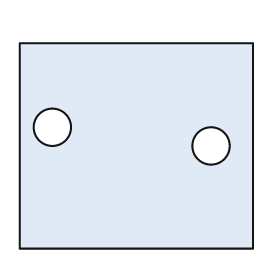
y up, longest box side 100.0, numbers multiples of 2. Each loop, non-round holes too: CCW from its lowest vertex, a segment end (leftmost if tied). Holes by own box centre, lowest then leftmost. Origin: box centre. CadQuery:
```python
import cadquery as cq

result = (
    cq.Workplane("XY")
    .moveTo(-50.0, -44.0)
    .lineTo(50.0, -44.0)
    .lineTo(50.0, 44.0)
    .lineTo(-50.0, 44.0)
    .close()
    .moveTo(32.0, 0.0)
    .circle(8.0)
    .moveTo(-36.0, 8.0)
    .circle(8.0)
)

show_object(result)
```